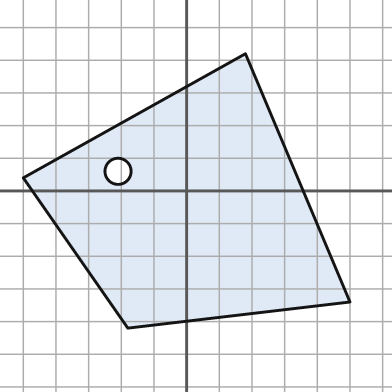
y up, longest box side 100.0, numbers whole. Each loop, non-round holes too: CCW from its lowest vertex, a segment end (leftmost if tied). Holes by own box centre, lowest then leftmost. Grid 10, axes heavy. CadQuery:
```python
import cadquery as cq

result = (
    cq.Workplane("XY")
    .moveTo(-18.0, -42.0)
    .lineTo(50.0, -34.0)
    .lineTo(18.0, 42.0)
    .lineTo(-50.0, 4.0)
    .close()
    .moveTo(-21.0, 6.0)
    .circle(4.0)
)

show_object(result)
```